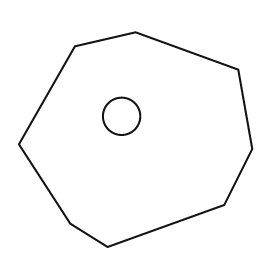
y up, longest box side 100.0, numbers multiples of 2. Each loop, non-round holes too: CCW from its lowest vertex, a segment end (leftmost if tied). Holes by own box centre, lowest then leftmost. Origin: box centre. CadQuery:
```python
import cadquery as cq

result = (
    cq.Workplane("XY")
    .moveTo(-12.0, -46.0)
    .lineTo(38.0, -28.0)
    .lineTo(50.0, -4.0)
    .lineTo(44.0, 30.0)
    .lineTo(0.0, 46.0)
    .lineTo(-26.0, 40.0)
    .lineTo(-50.0, -2.0)
    .lineTo(-28.0, -36.0)
    .close()
    .moveTo(-6.0, 10.0)
    .circle(8.0)
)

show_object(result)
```